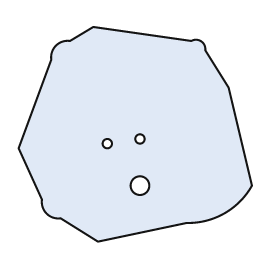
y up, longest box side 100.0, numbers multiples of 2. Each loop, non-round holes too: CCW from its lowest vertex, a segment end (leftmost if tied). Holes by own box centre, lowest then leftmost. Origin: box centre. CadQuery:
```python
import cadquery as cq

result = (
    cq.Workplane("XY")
    .moveTo(-16.0, -46.0)
    .lineTo(22.0, -38.0)
    .threePointArc((38.0, -34.0), (50.0, -22.0))
    .lineTo(40.0, 20.0)
    .lineTo(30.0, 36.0)
    .threePointArc((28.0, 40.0), (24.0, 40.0))
    .lineTo(-18.0, 46.0)
    .lineTo(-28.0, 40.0)
    .threePointArc((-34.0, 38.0), (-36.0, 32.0))
    .lineTo(-50.0, -6.0)
    .lineTo(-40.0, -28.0)
    .threePointArc((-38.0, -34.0), (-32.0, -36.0))
    .close()
    .moveTo(2.0, -22.0)
    .circle(4.0)
    .moveTo(-12.0, -4.0)
    .circle(2.0)
    .moveTo(2.0, -2.0)
    .circle(2.0)
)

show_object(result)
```